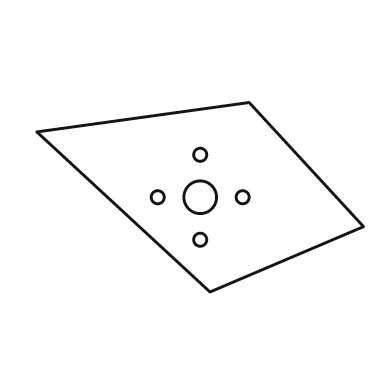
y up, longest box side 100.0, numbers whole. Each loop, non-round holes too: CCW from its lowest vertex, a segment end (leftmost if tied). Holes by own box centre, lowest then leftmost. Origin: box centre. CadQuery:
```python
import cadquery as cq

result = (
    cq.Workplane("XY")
    .moveTo(3.0, -29.0)
    .lineTo(50.0, -9.0)
    .lineTo(15.0, 29.0)
    .lineTo(-50.0, 20.0)
    .close()
    .moveTo(0.0, -13.0)
    .circle(2.0)
    .moveTo(-13.0, 0.0)
    .circle(2.0)
    .moveTo(0.0, 0.0)
    .circle(5.0)
    .moveTo(13.0, 0.0)
    .circle(2.0)
    .moveTo(0.0, 13.0)
    .circle(2.0)
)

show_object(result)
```